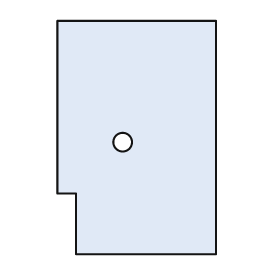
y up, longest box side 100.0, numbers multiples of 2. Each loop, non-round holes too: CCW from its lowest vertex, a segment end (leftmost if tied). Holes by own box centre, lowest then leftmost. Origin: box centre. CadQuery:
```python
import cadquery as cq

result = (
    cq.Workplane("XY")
    .moveTo(-26.0, -50.0)
    .lineTo(34.0, -50.0)
    .lineTo(34.0, 50.0)
    .lineTo(-34.0, 50.0)
    .lineTo(-34.0, -24.0)
    .lineTo(-26.0, -24.0)
    .close()
    .moveTo(-6.0, -2.0)
    .circle(4.0)
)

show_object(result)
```